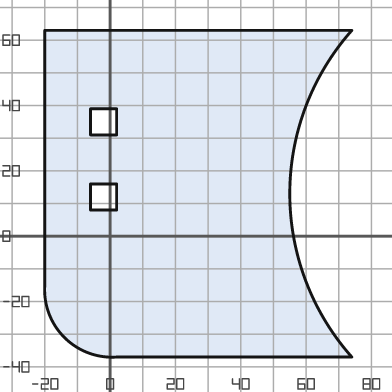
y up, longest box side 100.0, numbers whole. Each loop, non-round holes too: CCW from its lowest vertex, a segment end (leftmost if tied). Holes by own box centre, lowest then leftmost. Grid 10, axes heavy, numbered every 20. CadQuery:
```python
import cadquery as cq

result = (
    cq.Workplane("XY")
    .moveTo(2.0, -37.0)
    .lineTo(74.0, -37.0)
    .threePointArc((55.0, 13.0), (74.0, 63.0))
    .lineTo(-20.0, 63.0)
    .lineTo(-20.0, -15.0)
    .threePointArc((-14.0, -31.0), (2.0, -37.0))
    .close()
    .moveTo(-6.0, 8.0)
    .lineTo(2.0, 8.0)
    .lineTo(2.0, 16.0)
    .lineTo(-6.0, 16.0)
    .close()
    .moveTo(-6.0, 31.0)
    .lineTo(2.0, 31.0)
    .lineTo(2.0, 39.0)
    .lineTo(-6.0, 39.0)
    .close()
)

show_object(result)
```